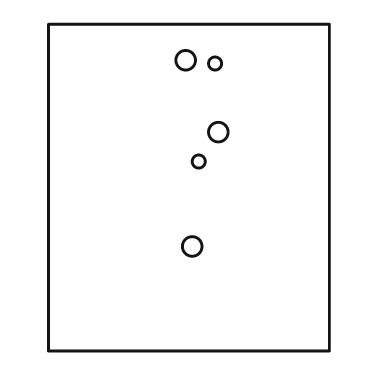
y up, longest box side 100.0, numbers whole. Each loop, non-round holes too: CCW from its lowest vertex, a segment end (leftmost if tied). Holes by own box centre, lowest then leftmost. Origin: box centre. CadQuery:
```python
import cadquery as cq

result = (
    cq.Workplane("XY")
    .moveTo(-43.0, -50.0)
    .lineTo(43.0, -50.0)
    .lineTo(43.0, 50.0)
    .lineTo(-43.0, 50.0)
    .close()
    .moveTo(1.0, -18.0)
    .circle(3.0)
    .moveTo(3.0, 8.0)
    .circle(2.0)
    .moveTo(9.0, 17.0)
    .circle(3.0)
    .moveTo(8.0, 38.0)
    .circle(2.0)
    .moveTo(-1.0, 39.0)
    .circle(3.0)
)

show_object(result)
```